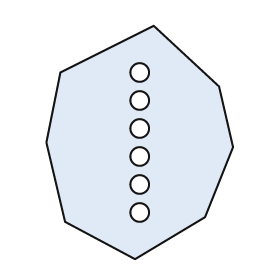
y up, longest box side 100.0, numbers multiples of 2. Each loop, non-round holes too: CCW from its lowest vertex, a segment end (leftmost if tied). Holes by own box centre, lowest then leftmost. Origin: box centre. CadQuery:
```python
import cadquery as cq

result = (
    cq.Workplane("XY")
    .moveTo(-2.0, -50.0)
    .lineTo(28.0, -32.0)
    .lineTo(40.0, -2.0)
    .lineTo(34.0, 24.0)
    .lineTo(6.0, 50.0)
    .lineTo(-34.0, 30.0)
    .lineTo(-40.0, 0.0)
    .lineTo(-32.0, -34.0)
    .close()
    .moveTo(0.0, -30.0)
    .circle(4.0)
    .moveTo(0.0, -18.0)
    .circle(4.0)
    .moveTo(0.0, -6.0)
    .circle(4.0)
    .moveTo(0.0, 6.0)
    .circle(4.0)
    .moveTo(0.0, 18.0)
    .circle(4.0)
    .moveTo(0.0, 30.0)
    .circle(4.0)
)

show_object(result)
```